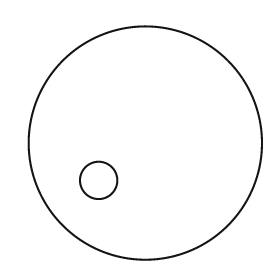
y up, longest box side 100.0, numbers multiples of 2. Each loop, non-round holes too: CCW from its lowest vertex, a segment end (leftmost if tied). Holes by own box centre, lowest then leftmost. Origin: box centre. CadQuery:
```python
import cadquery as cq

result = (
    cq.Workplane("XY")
    .moveTo(0.0, 0.0)
    .circle(50.0)
    .moveTo(-20.0, -16.0)
    .circle(8.0)
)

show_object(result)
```